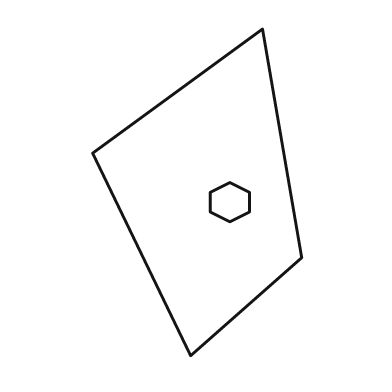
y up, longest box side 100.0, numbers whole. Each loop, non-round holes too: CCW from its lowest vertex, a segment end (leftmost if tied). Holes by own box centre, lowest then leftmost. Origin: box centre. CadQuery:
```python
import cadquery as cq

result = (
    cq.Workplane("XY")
    .moveTo(-2.0, -50.0)
    .lineTo(32.0, -20.0)
    .lineTo(20.0, 50.0)
    .lineTo(-32.0, 12.0)
    .close()
    .moveTo(10.0, -9.0)
    .lineTo(16.0, -6.0)
    .lineTo(16.0, 0.0)
    .lineTo(10.0, 3.0)
    .lineTo(4.0, 0.0)
    .lineTo(4.0, -6.0)
    .close()
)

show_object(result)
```